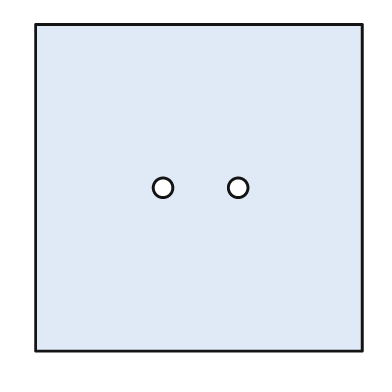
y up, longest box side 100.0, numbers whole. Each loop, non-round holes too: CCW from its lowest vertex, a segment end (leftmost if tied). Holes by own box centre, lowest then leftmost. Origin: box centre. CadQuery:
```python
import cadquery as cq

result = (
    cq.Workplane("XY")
    .moveTo(-50.0, -50.0)
    .lineTo(50.0, -50.0)
    .lineTo(50.0, 50.0)
    .lineTo(-50.0, 50.0)
    .close()
    .moveTo(-11.0, 0.0)
    .circle(3.0)
    .moveTo(12.0, 0.0)
    .circle(3.0)
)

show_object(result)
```